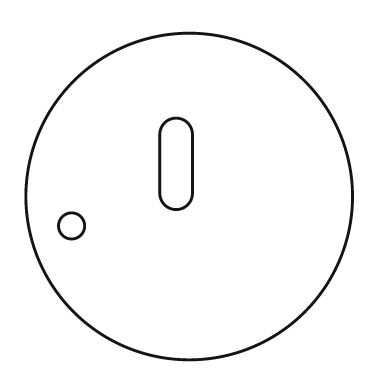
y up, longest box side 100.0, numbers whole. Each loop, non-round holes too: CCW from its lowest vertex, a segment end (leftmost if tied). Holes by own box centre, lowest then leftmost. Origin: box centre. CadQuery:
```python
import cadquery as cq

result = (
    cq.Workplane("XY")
    .moveTo(0.0, 0.0)
    .circle(50.0)
    .moveTo(-36.0, -9.0)
    .circle(4.0)
    .moveTo(-9.0, 1.0)
    .threePointArc((-4.0, -4.0), (1.0, 1.0))
    .lineTo(1.0, 19.0)
    .threePointArc((-4.0, 24.0), (-9.0, 19.0))
    .close()
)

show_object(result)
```